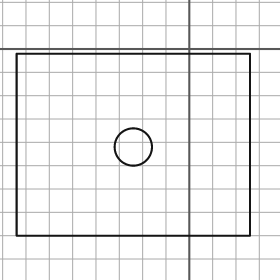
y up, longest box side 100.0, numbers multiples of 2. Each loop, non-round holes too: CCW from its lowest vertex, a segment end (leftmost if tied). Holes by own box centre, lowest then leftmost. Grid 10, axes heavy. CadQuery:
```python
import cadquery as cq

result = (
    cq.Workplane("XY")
    .moveTo(-74.0, -80.0)
    .lineTo(26.0, -80.0)
    .lineTo(26.0, -2.0)
    .lineTo(-74.0, -2.0)
    .close()
    .moveTo(-24.0, -42.0)
    .circle(8.0)
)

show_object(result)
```